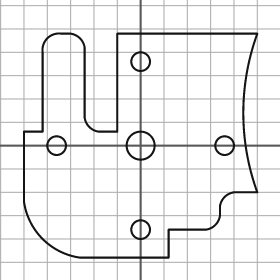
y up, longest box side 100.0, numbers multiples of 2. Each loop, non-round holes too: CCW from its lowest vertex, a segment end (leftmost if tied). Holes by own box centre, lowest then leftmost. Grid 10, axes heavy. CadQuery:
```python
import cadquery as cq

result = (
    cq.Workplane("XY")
    .moveTo(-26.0, -48.0)
    .lineTo(12.0, -48.0)
    .lineTo(12.0, -36.0)
    .lineTo(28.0, -36.0)
    .threePointArc((32.0, -34.0), (34.0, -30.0))
    .lineTo(34.0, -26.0)
    .threePointArc((36.0, -22.0), (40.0, -20.0))
    .lineTo(50.0, -20.0)
    .threePointArc((44.0, 14.0), (50.0, 48.0))
    .lineTo(-10.0, 48.0)
    .lineTo(-10.0, 6.0)
    .lineTo(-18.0, 6.0)
    .threePointArc((-22.0, 8.0), (-24.0, 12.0))
    .lineTo(-24.0, 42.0)
    .threePointArc((-26.0, 46.0), (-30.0, 48.0))
    .lineTo(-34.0, 48.0)
    .threePointArc((-40.0, 46.0), (-42.0, 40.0))
    .lineTo(-42.0, 6.0)
    .lineTo(-50.0, 6.0)
    .lineTo(-50.0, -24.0)
    .threePointArc((-42.0, -40.0), (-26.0, -48.0))
    .close()
    .moveTo(0.0, -36.0)
    .circle(4.0)
    .moveTo(-36.0, 0.0)
    .circle(4.0)
    .moveTo(0.0, 0.0)
    .circle(6.0)
    .moveTo(36.0, 0.0)
    .circle(4.0)
    .moveTo(0.0, 36.0)
    .circle(4.0)
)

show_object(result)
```